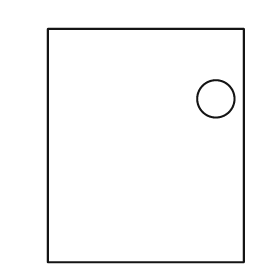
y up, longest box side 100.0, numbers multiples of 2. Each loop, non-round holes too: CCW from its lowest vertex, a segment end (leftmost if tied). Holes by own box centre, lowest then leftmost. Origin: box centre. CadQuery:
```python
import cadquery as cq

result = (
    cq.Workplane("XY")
    .moveTo(-42.0, -50.0)
    .lineTo(42.0, -50.0)
    .lineTo(42.0, 50.0)
    .lineTo(-42.0, 50.0)
    .close()
    .moveTo(30.0, 20.0)
    .circle(8.0)
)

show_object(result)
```